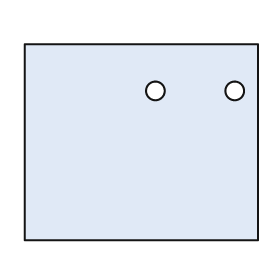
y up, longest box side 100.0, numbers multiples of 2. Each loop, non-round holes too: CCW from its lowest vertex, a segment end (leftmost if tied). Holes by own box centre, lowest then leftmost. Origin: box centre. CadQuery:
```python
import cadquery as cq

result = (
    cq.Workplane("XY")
    .moveTo(-50.0, -42.0)
    .lineTo(50.0, -42.0)
    .lineTo(50.0, 42.0)
    .lineTo(-50.0, 42.0)
    .close()
    .moveTo(6.0, 22.0)
    .circle(4.0)
    .moveTo(40.0, 22.0)
    .circle(4.0)
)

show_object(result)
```